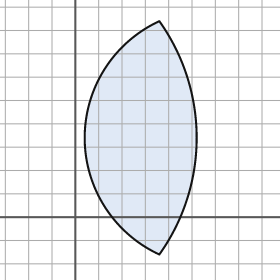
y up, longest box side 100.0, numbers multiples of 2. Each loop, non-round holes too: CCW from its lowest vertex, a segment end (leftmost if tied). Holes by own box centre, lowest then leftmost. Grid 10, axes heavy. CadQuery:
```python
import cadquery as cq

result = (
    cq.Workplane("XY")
    .moveTo(36.0, -16.0)
    .threePointArc((52.0, 34.0), (36.0, 84.0))
    .threePointArc((4.0, 34.0), (36.0, -16.0))
    .close()
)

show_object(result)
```